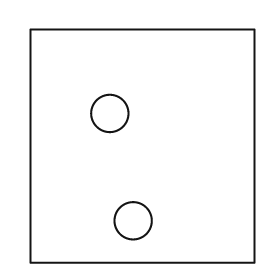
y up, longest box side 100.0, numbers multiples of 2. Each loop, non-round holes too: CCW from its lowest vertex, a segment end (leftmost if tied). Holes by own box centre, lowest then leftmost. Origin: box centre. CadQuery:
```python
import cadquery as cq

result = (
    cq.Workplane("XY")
    .moveTo(-48.0, -50.0)
    .lineTo(48.0, -50.0)
    .lineTo(48.0, 50.0)
    .lineTo(-48.0, 50.0)
    .close()
    .moveTo(-4.0, -32.0)
    .circle(8.0)
    .moveTo(-14.0, 14.0)
    .circle(8.0)
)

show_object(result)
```